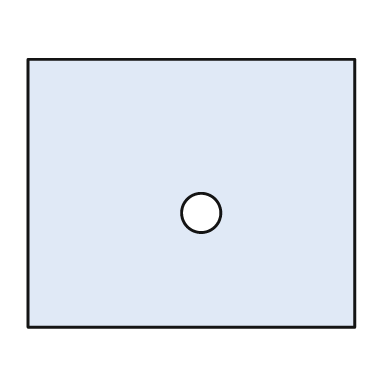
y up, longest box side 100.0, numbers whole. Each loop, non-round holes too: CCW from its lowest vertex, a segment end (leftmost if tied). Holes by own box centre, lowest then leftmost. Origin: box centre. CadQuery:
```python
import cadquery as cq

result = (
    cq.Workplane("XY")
    .moveTo(-50.0, -41.0)
    .lineTo(50.0, -41.0)
    .lineTo(50.0, 41.0)
    .lineTo(-50.0, 41.0)
    .close()
    .moveTo(3.0, -6.0)
    .circle(6.0)
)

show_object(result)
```